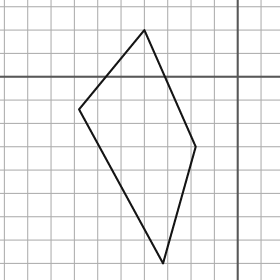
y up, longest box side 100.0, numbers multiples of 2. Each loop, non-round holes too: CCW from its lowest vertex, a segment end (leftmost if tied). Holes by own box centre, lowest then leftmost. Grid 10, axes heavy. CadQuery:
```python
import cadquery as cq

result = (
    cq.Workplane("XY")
    .moveTo(-32.0, -80.0)
    .lineTo(-18.0, -30.0)
    .lineTo(-40.0, 20.0)
    .lineTo(-68.0, -14.0)
    .close()
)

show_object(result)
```